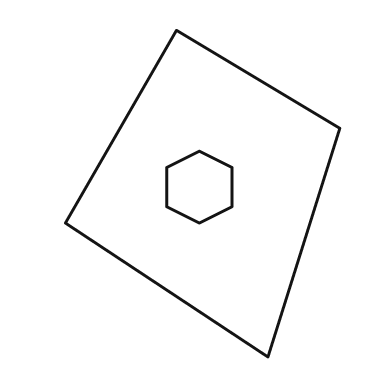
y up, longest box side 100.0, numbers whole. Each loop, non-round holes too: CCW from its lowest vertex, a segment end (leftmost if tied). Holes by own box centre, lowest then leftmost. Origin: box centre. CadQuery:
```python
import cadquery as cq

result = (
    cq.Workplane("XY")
    .moveTo(20.0, -50.0)
    .lineTo(42.0, 20.0)
    .lineTo(-8.0, 50.0)
    .lineTo(-42.0, -9.0)
    .close()
    .moveTo(-1.0, -9.0)
    .lineTo(9.0, -4.0)
    .lineTo(9.0, 8.0)
    .lineTo(-1.0, 13.0)
    .lineTo(-11.0, 8.0)
    .lineTo(-11.0, -4.0)
    .close()
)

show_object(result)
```